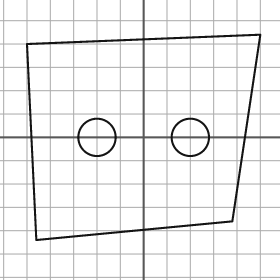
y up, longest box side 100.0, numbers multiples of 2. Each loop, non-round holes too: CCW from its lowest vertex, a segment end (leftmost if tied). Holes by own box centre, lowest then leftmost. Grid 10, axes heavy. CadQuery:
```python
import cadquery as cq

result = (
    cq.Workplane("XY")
    .moveTo(-46.0, -44.0)
    .lineTo(38.0, -36.0)
    .lineTo(50.0, 44.0)
    .lineTo(-50.0, 40.0)
    .close()
    .moveTo(-20.0, 0.0)
    .circle(8.0)
    .moveTo(20.0, 0.0)
    .circle(8.0)
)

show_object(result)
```